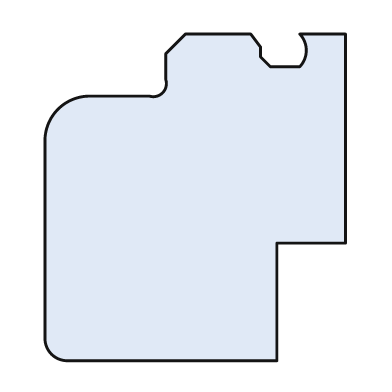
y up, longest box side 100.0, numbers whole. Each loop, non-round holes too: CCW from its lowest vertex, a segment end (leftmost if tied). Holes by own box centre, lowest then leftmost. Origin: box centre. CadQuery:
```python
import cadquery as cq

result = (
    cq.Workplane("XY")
    .moveTo(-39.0, -50.0)
    .lineTo(25.0, -50.0)
    .lineTo(25.0, -14.0)
    .lineTo(46.0, -14.0)
    .lineTo(46.0, 50.0)
    .lineTo(32.0, 50.0)
    .threePointArc((34.0, 45.0), (32.0, 40.0))
    .lineTo(23.0, 40.0)
    .lineTo(20.0, 43.0)
    .lineTo(20.0, 46.0)
    .lineTo(17.0, 50.0)
    .lineTo(-3.0, 50.0)
    .lineTo(-9.0, 44.0)
    .lineTo(-9.0, 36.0)
    .threePointArc((-10.0, 32.0), (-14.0, 31.0))
    .lineTo(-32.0, 31.0)
    .threePointArc((-42.0, 27.0), (-46.0, 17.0))
    .lineTo(-46.0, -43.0)
    .threePointArc((-44.0, -48.0), (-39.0, -50.0))
    .close()
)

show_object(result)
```